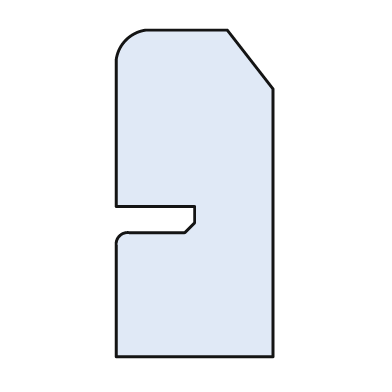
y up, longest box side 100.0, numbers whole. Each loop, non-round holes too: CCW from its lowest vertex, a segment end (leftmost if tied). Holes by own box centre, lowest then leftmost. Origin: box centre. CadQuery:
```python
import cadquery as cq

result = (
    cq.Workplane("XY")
    .moveTo(-24.0, -50.0)
    .lineTo(24.0, -50.0)
    .lineTo(24.0, 32.0)
    .lineTo(10.0, 50.0)
    .lineTo(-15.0, 50.0)
    .threePointArc((-21.0, 47.0), (-24.0, 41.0))
    .lineTo(-24.0, -4.0)
    .lineTo(0.0, -4.0)
    .lineTo(0.0, -9.0)
    .lineTo(-3.0, -12.0)
    .lineTo(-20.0, -12.0)
    .threePointArc((-23.0, -13.0), (-24.0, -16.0))
    .close()
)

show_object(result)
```